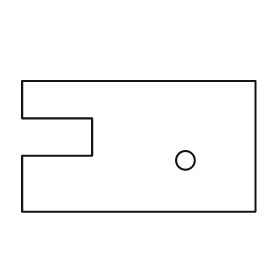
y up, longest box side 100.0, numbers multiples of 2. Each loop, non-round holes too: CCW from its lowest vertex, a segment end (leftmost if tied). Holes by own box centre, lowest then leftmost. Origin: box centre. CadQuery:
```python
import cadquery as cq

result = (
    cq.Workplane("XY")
    .moveTo(-50.0, -28.0)
    .lineTo(50.0, -28.0)
    .lineTo(50.0, 28.0)
    .lineTo(-50.0, 28.0)
    .lineTo(-50.0, 12.0)
    .lineTo(-20.0, 12.0)
    .lineTo(-20.0, -4.0)
    .lineTo(-50.0, -4.0)
    .close()
    .moveTo(20.0, -6.0)
    .circle(4.0)
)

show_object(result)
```